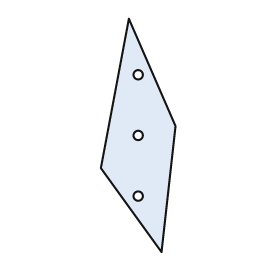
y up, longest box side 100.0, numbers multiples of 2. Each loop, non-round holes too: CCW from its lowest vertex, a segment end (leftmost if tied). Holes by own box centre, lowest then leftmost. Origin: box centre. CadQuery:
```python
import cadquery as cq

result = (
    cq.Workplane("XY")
    .moveTo(10.0, -50.0)
    .lineTo(16.0, 4.0)
    .lineTo(-4.0, 50.0)
    .lineTo(-16.0, -14.0)
    .close()
    .moveTo(0.0, -26.0)
    .circle(2.0)
    .moveTo(0.0, 0.0)
    .circle(2.0)
    .moveTo(0.0, 26.0)
    .circle(2.0)
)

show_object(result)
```